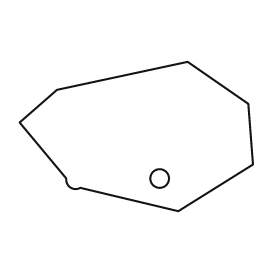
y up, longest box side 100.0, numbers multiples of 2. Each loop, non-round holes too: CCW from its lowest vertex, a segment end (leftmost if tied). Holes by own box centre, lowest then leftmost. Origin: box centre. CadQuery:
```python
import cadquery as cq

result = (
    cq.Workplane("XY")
    .moveTo(18.0, -32.0)
    .lineTo(50.0, -12.0)
    .lineTo(48.0, 14.0)
    .lineTo(22.0, 32.0)
    .lineTo(-34.0, 20.0)
    .lineTo(-50.0, 6.0)
    .lineTo(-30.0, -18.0)
    .threePointArc((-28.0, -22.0), (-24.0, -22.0))
    .close()
    .moveTo(10.0, -18.0)
    .circle(4.0)
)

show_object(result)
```